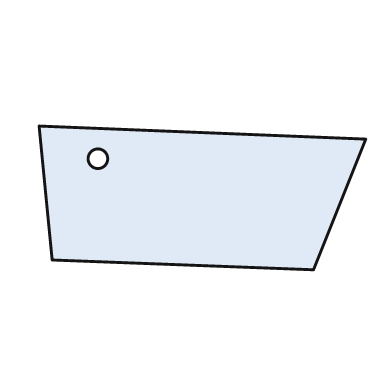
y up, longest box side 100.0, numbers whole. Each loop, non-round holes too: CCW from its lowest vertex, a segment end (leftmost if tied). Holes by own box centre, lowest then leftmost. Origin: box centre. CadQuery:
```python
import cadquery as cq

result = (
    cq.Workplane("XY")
    .moveTo(34.0, -22.0)
    .lineTo(50.0, 18.0)
    .lineTo(-50.0, 22.0)
    .lineTo(-46.0, -19.0)
    .close()
    .moveTo(-32.0, 12.0)
    .circle(3.0)
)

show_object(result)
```